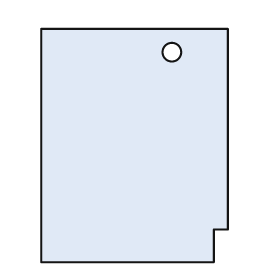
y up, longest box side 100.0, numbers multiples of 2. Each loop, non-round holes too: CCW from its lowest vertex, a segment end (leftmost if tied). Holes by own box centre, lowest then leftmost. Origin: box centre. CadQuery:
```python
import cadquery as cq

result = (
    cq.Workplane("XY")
    .moveTo(-40.0, -50.0)
    .lineTo(34.0, -50.0)
    .lineTo(34.0, -36.0)
    .lineTo(40.0, -36.0)
    .lineTo(40.0, 50.0)
    .lineTo(-40.0, 50.0)
    .close()
    .moveTo(16.0, 40.0)
    .circle(4.0)
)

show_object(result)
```